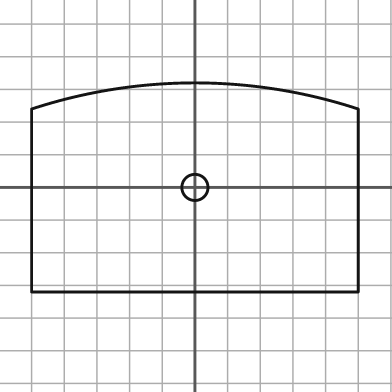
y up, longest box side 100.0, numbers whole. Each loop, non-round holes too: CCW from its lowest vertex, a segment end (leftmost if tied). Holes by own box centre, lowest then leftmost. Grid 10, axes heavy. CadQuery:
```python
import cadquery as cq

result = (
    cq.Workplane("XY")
    .moveTo(-50.0, -32.0)
    .lineTo(50.0, -32.0)
    .lineTo(50.0, 24.0)
    .threePointArc((0.0, 32.0), (-50.0, 24.0))
    .close()
    .moveTo(0.0, 0.0)
    .circle(4.0)
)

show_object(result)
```